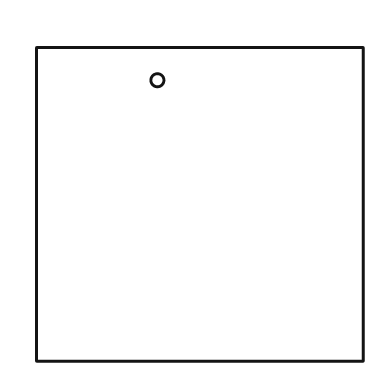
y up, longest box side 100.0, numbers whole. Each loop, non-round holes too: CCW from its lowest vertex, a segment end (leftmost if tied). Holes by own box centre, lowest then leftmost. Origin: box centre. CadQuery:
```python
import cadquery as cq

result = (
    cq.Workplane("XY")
    .moveTo(-50.0, -48.0)
    .lineTo(50.0, -48.0)
    .lineTo(50.0, 48.0)
    .lineTo(-50.0, 48.0)
    .close()
    .moveTo(-13.0, 38.0)
    .circle(2.0)
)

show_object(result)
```